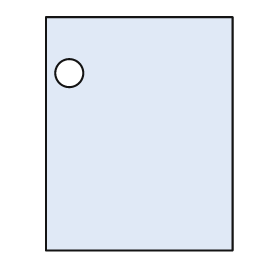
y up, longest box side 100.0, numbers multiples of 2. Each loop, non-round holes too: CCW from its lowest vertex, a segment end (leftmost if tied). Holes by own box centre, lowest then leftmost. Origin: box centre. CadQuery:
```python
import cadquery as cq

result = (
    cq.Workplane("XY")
    .moveTo(-40.0, -50.0)
    .lineTo(40.0, -50.0)
    .lineTo(40.0, 50.0)
    .lineTo(-40.0, 50.0)
    .close()
    .moveTo(-30.0, 26.0)
    .circle(6.0)
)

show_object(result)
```